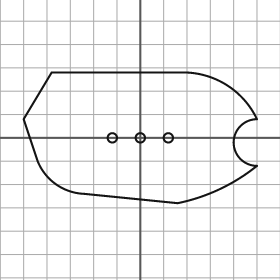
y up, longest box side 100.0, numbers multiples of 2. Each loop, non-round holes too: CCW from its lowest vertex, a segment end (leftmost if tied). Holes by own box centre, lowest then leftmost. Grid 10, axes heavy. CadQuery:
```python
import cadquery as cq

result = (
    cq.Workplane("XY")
    .moveTo(16.0, -28.0)
    .threePointArc((34.0, -22.0), (50.0, -12.0))
    .threePointArc((40.0, -2.0), (50.0, 8.0))
    .threePointArc((38.0, 22.0), (20.0, 28.0))
    .lineTo(-38.0, 28.0)
    .lineTo(-50.0, 8.0)
    .lineTo(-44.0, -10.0)
    .threePointArc((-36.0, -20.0), (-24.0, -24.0))
    .close()
    .moveTo(-12.0, 0.0)
    .circle(2.0)
    .moveTo(0.0, 0.0)
    .circle(2.0)
    .moveTo(12.0, 0.0)
    .circle(2.0)
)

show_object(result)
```